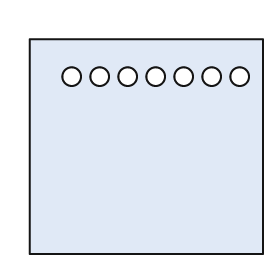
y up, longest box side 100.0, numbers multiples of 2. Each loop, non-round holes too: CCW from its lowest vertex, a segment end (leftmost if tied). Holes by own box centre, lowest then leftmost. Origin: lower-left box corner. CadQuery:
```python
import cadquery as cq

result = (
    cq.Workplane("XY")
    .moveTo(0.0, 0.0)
    .lineTo(100.0, 0.0)
    .lineTo(100.0, 92.0)
    .lineTo(0.0, 92.0)
    .close()
    .moveTo(18.0, 76.0)
    .circle(4.0)
    .moveTo(30.0, 76.0)
    .circle(4.0)
    .moveTo(42.0, 76.0)
    .circle(4.0)
    .moveTo(54.0, 76.0)
    .circle(4.0)
    .moveTo(66.0, 76.0)
    .circle(4.0)
    .moveTo(78.0, 76.0)
    .circle(4.0)
    .moveTo(90.0, 76.0)
    .circle(4.0)
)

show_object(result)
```